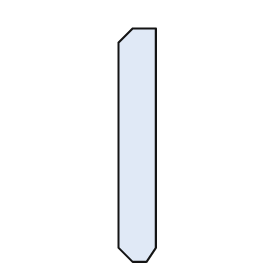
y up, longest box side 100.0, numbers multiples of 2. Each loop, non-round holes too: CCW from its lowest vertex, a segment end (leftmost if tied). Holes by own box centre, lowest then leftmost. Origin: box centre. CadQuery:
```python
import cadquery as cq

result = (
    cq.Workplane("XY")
    .moveTo(-2.0, -50.0)
    .lineTo(4.0, -50.0)
    .lineTo(8.0, -44.0)
    .lineTo(8.0, 50.0)
    .lineTo(-2.0, 50.0)
    .lineTo(-8.0, 44.0)
    .lineTo(-8.0, -44.0)
    .close()
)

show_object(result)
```